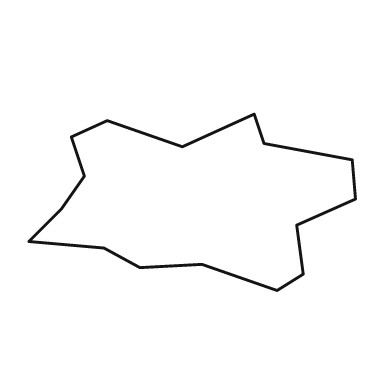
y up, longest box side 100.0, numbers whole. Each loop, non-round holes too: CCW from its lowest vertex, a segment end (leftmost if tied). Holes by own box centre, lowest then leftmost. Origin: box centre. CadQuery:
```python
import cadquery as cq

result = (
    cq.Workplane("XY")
    .moveTo(26.0, -27.0)
    .lineTo(34.0, -22.0)
    .lineTo(32.0, -7.0)
    .lineTo(50.0, 1.0)
    .lineTo(49.0, 13.0)
    .lineTo(22.0, 18.0)
    .lineTo(19.0, 27.0)
    .lineTo(-3.0, 17.0)
    .lineTo(-26.0, 25.0)
    .lineTo(-37.0, 20.0)
    .lineTo(-33.0, 8.0)
    .lineTo(-40.0, -2.0)
    .lineTo(-50.0, -12.0)
    .lineTo(-27.0, -14.0)
    .lineTo(-16.0, -20.0)
    .lineTo(3.0, -19.0)
    .close()
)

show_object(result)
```